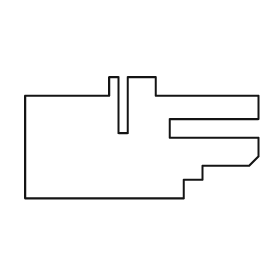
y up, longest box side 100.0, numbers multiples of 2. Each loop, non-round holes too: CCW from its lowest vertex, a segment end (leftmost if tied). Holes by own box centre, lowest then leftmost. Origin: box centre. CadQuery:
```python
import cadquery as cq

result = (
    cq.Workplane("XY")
    .moveTo(-50.0, -26.0)
    .lineTo(18.0, -26.0)
    .lineTo(18.0, -18.0)
    .lineTo(26.0, -18.0)
    .lineTo(26.0, -12.0)
    .lineTo(46.0, -12.0)
    .lineTo(50.0, -8.0)
    .lineTo(50.0, 0.0)
    .lineTo(12.0, 0.0)
    .lineTo(12.0, 8.0)
    .lineTo(50.0, 8.0)
    .lineTo(50.0, 18.0)
    .lineTo(6.0, 18.0)
    .lineTo(6.0, 26.0)
    .lineTo(-6.0, 26.0)
    .lineTo(-6.0, 2.0)
    .lineTo(-10.0, 2.0)
    .lineTo(-10.0, 26.0)
    .lineTo(-14.0, 26.0)
    .lineTo(-14.0, 18.0)
    .lineTo(-50.0, 18.0)
    .close()
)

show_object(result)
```